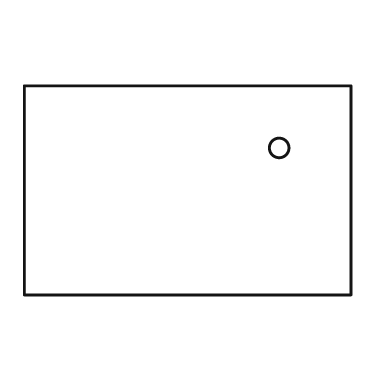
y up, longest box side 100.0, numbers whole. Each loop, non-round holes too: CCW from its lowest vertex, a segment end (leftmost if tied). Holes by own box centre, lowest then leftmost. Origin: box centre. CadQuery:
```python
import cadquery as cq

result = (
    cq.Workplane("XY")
    .moveTo(-50.0, -32.0)
    .lineTo(50.0, -32.0)
    .lineTo(50.0, 32.0)
    .lineTo(-50.0, 32.0)
    .close()
    .moveTo(28.0, 13.0)
    .circle(3.0)
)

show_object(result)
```